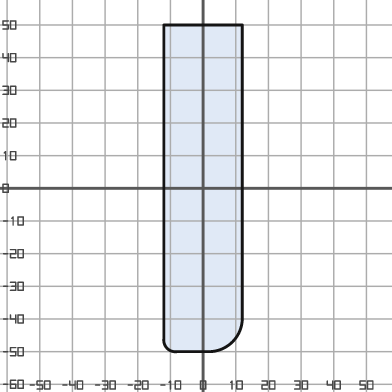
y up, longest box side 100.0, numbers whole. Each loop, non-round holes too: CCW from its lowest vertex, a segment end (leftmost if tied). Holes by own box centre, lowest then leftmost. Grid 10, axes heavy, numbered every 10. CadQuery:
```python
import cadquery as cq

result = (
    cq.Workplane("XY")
    .moveTo(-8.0, -50.0)
    .lineTo(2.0, -50.0)
    .threePointArc((9.0, -47.0), (12.0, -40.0))
    .lineTo(12.0, 50.0)
    .lineTo(-12.0, 50.0)
    .lineTo(-12.0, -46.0)
    .threePointArc((-11.0, -49.0), (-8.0, -50.0))
    .close()
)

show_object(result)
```